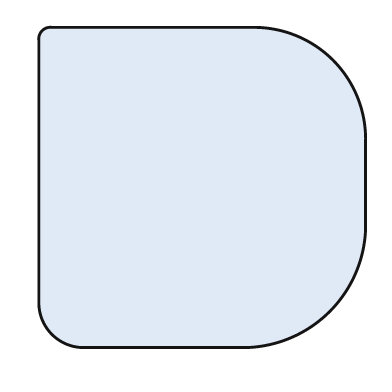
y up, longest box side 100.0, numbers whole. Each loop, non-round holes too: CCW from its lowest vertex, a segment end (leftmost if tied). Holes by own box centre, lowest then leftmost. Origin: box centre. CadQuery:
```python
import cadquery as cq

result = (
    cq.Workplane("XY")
    .moveTo(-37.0, -49.0)
    .lineTo(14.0, -49.0)
    .threePointArc((39.0, -38.0), (50.0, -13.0))
    .lineTo(50.0, 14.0)
    .threePointArc((40.0, 39.0), (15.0, 49.0))
    .lineTo(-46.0, 49.0)
    .threePointArc((-49.0, 48.0), (-50.0, 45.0))
    .lineTo(-50.0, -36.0)
    .threePointArc((-46.0, -45.0), (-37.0, -49.0))
    .close()
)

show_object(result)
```